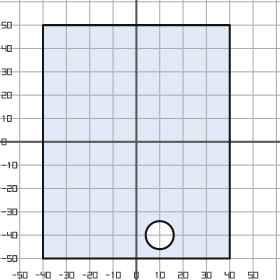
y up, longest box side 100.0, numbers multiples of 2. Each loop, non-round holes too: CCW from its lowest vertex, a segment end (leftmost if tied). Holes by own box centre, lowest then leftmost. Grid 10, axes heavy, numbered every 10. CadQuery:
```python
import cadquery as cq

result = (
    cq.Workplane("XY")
    .moveTo(-40.0, -50.0)
    .lineTo(40.0, -50.0)
    .lineTo(40.0, 50.0)
    .lineTo(-40.0, 50.0)
    .close()
    .moveTo(10.0, -40.0)
    .circle(6.0)
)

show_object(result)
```